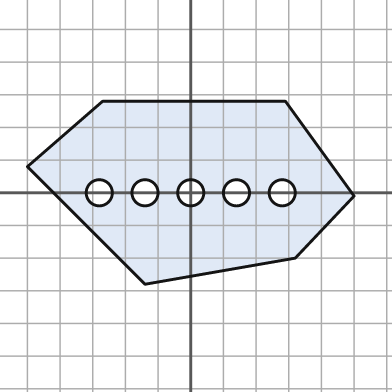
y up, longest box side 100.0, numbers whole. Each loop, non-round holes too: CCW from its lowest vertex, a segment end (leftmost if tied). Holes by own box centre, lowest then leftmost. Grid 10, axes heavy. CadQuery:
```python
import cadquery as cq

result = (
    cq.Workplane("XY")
    .moveTo(-14.0, -28.0)
    .lineTo(32.0, -20.0)
    .lineTo(50.0, -1.0)
    .lineTo(29.0, 28.0)
    .lineTo(-27.0, 28.0)
    .lineTo(-50.0, 8.0)
    .close()
    .moveTo(-28.0, 0.0)
    .circle(4.0)
    .moveTo(-14.0, 0.0)
    .circle(4.0)
    .moveTo(0.0, 0.0)
    .circle(4.0)
    .moveTo(14.0, 0.0)
    .circle(4.0)
    .moveTo(28.0, 0.0)
    .circle(4.0)
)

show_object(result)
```